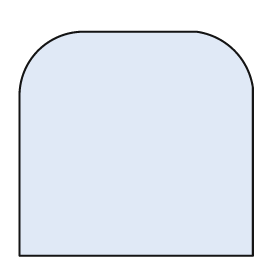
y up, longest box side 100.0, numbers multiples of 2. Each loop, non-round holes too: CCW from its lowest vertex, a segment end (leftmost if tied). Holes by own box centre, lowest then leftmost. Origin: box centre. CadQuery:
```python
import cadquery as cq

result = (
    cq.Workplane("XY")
    .moveTo(-50.0, -48.0)
    .lineTo(50.0, -48.0)
    .lineTo(50.0, 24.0)
    .threePointArc((42.0, 40.0), (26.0, 48.0))
    .lineTo(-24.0, 48.0)
    .threePointArc((-42.0, 40.0), (-50.0, 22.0))
    .close()
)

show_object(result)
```